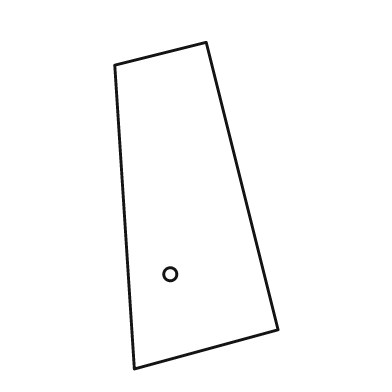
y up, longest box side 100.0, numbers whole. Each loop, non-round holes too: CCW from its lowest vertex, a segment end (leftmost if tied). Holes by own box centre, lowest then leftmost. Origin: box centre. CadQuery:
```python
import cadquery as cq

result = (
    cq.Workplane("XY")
    .moveTo(-19.0, -50.0)
    .lineTo(25.0, -38.0)
    .lineTo(3.0, 50.0)
    .lineTo(-25.0, 43.0)
    .close()
    .moveTo(-8.0, -21.0)
    .circle(2.0)
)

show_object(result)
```